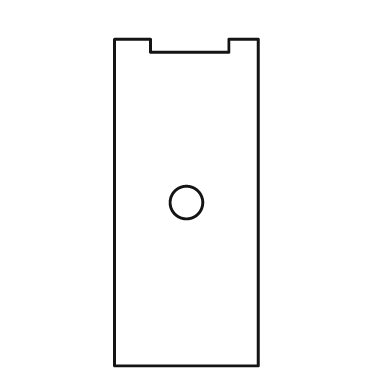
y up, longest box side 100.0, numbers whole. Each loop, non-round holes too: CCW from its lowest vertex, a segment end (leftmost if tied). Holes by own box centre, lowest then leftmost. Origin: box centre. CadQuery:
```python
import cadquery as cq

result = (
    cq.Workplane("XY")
    .moveTo(-22.0, -50.0)
    .lineTo(22.0, -50.0)
    .lineTo(22.0, 50.0)
    .lineTo(13.0, 50.0)
    .lineTo(13.0, 46.0)
    .lineTo(-11.0, 46.0)
    .lineTo(-11.0, 50.0)
    .lineTo(-22.0, 50.0)
    .close()
    .moveTo(0.0, 0.0)
    .circle(5.0)
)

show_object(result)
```